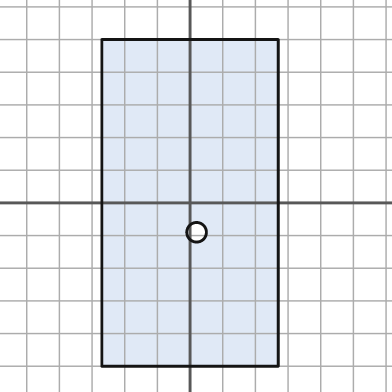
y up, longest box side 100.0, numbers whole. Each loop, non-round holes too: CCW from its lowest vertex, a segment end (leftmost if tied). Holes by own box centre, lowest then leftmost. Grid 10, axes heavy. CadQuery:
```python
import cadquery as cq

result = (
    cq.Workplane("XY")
    .moveTo(-27.0, -50.0)
    .lineTo(27.0, -50.0)
    .lineTo(27.0, 50.0)
    .lineTo(-27.0, 50.0)
    .close()
    .moveTo(2.0, -9.0)
    .circle(3.0)
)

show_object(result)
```